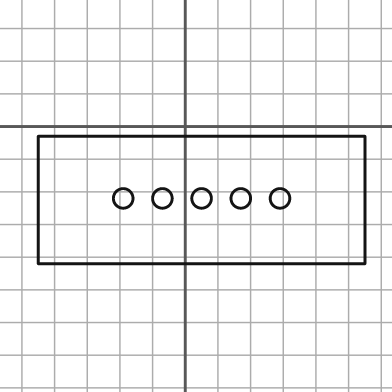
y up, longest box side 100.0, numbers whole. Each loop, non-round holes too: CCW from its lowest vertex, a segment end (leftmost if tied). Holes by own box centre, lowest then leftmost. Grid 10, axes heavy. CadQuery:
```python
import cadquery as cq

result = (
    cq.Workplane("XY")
    .moveTo(-45.0, -42.0)
    .lineTo(55.0, -42.0)
    .lineTo(55.0, -3.0)
    .lineTo(-45.0, -3.0)
    .close()
    .moveTo(-19.0, -22.0)
    .circle(3.0)
    .moveTo(-7.0, -22.0)
    .circle(3.0)
    .moveTo(5.0, -22.0)
    .circle(3.0)
    .moveTo(17.0, -22.0)
    .circle(3.0)
    .moveTo(29.0, -22.0)
    .circle(3.0)
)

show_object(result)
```